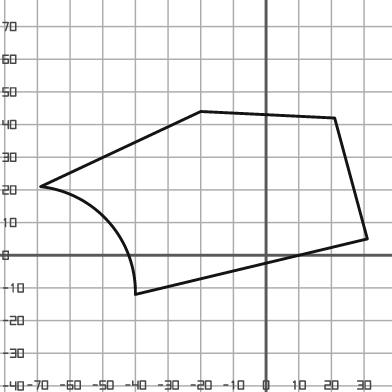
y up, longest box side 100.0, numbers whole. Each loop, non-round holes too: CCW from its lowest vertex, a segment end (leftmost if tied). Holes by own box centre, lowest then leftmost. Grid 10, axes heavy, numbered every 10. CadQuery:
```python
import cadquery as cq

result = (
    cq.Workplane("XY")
    .moveTo(-40.0, -12.0)
    .lineTo(31.0, 5.0)
    .lineTo(21.0, 42.0)
    .lineTo(-20.0, 44.0)
    .lineTo(-69.0, 21.0)
    .threePointArc((-48.0, 10.0), (-40.0, -12.0))
    .close()
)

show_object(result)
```